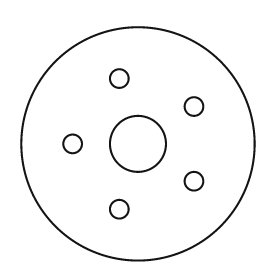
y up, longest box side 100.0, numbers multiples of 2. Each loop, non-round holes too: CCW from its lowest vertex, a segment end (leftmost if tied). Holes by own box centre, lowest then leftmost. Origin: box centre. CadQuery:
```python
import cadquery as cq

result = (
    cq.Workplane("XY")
    .moveTo(0.0, 0.0)
    .circle(50.0)
    .moveTo(-8.0, -28.0)
    .circle(4.0)
    .moveTo(24.0, -16.0)
    .circle(4.0)
    .moveTo(-28.0, 0.0)
    .circle(4.0)
    .moveTo(0.0, 0.0)
    .circle(12.0)
    .moveTo(24.0, 16.0)
    .circle(4.0)
    .moveTo(-8.0, 28.0)
    .circle(4.0)
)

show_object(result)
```